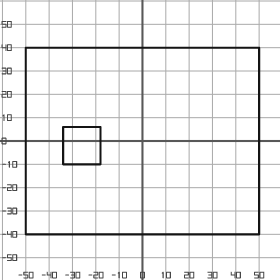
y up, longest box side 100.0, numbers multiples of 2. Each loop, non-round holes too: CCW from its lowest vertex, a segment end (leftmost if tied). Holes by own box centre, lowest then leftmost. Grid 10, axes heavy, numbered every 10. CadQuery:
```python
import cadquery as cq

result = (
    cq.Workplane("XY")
    .moveTo(-50.0, -40.0)
    .lineTo(50.0, -40.0)
    .lineTo(50.0, 40.0)
    .lineTo(-50.0, 40.0)
    .close()
    .moveTo(-34.0, -10.0)
    .lineTo(-18.0, -10.0)
    .lineTo(-18.0, 6.0)
    .lineTo(-34.0, 6.0)
    .close()
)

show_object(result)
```